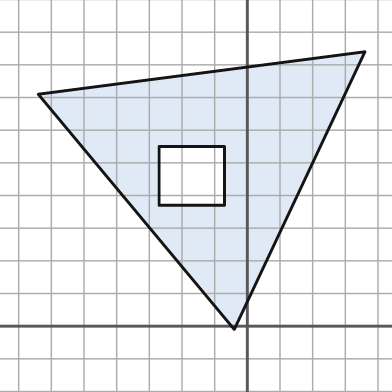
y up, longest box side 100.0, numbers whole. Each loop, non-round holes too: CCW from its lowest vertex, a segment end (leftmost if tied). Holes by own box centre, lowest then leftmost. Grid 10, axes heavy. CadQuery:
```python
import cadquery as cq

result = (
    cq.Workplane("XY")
    .moveTo(-4.0, -1.0)
    .lineTo(36.0, 84.0)
    .lineTo(-64.0, 71.0)
    .close()
    .moveTo(-27.0, 37.0)
    .lineTo(-7.0, 37.0)
    .lineTo(-7.0, 55.0)
    .lineTo(-27.0, 55.0)
    .close()
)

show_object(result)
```